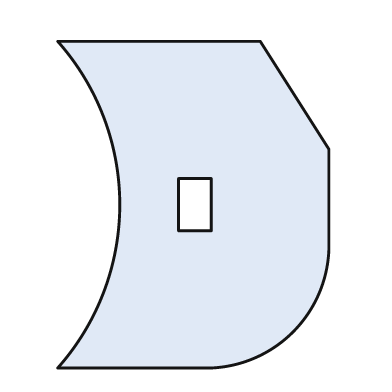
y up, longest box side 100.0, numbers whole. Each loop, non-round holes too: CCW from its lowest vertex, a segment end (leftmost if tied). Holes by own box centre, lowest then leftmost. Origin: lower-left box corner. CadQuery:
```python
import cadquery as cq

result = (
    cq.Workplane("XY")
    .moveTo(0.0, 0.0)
    .lineTo(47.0, 0.0)
    .threePointArc((72.0, 11.0), (83.0, 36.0))
    .lineTo(83.0, 67.0)
    .lineTo(62.0, 100.0)
    .lineTo(0.0, 100.0)
    .threePointArc((19.0, 50.0), (0.0, 0.0))
    .close()
    .moveTo(37.0, 42.0)
    .lineTo(47.0, 42.0)
    .lineTo(47.0, 58.0)
    .lineTo(37.0, 58.0)
    .close()
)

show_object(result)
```